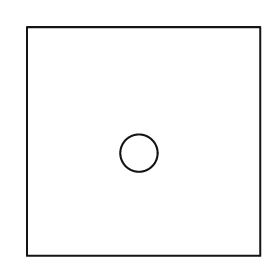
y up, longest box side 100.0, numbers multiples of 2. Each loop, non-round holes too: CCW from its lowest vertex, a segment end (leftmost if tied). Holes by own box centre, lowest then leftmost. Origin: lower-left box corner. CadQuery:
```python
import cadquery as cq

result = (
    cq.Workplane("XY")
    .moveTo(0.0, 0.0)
    .lineTo(100.0, 0.0)
    .lineTo(100.0, 98.0)
    .lineTo(0.0, 98.0)
    .close()
    .moveTo(48.0, 44.0)
    .circle(8.0)
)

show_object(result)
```